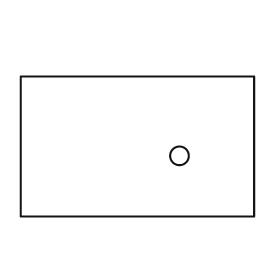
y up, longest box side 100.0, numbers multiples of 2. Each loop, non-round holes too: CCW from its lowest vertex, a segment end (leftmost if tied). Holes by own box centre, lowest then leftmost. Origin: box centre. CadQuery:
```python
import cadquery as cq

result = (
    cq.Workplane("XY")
    .moveTo(-50.0, -30.0)
    .lineTo(50.0, -30.0)
    .lineTo(50.0, 30.0)
    .lineTo(-50.0, 30.0)
    .close()
    .moveTo(18.0, -4.0)
    .circle(4.0)
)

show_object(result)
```